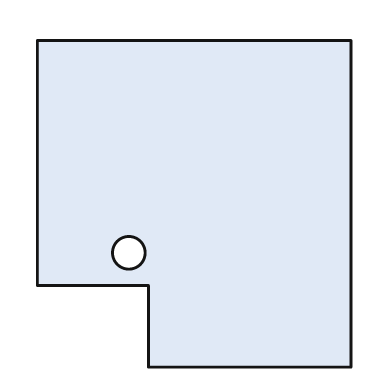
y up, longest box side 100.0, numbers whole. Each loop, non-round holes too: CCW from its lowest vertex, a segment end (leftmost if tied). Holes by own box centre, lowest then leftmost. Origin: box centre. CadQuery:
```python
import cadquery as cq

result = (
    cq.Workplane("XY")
    .moveTo(-14.0, -50.0)
    .lineTo(48.0, -50.0)
    .lineTo(48.0, 50.0)
    .lineTo(-48.0, 50.0)
    .lineTo(-48.0, -25.0)
    .lineTo(-14.0, -25.0)
    .close()
    .moveTo(-20.0, -15.0)
    .circle(5.0)
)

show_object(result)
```